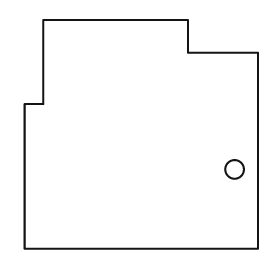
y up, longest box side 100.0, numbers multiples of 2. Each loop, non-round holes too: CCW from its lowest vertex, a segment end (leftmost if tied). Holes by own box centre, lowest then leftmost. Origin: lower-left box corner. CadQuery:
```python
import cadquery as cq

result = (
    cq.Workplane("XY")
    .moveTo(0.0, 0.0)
    .lineTo(100.0, 0.0)
    .lineTo(100.0, 84.0)
    .lineTo(70.0, 84.0)
    .lineTo(70.0, 98.0)
    .lineTo(8.0, 98.0)
    .lineTo(8.0, 62.0)
    .lineTo(0.0, 62.0)
    .close()
    .moveTo(90.0, 34.0)
    .circle(4.0)
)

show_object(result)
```